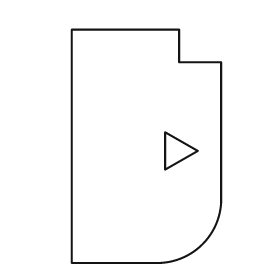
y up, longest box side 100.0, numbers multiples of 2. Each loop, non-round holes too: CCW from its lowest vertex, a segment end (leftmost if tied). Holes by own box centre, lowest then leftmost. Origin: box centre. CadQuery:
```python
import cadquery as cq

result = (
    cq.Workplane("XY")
    .moveTo(-32.0, -50.0)
    .lineTo(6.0, -50.0)
    .threePointArc((24.0, -42.0), (32.0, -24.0))
    .lineTo(32.0, 36.0)
    .lineTo(14.0, 36.0)
    .lineTo(14.0, 50.0)
    .lineTo(-32.0, 50.0)
    .close()
    .moveTo(8.0, -10.0)
    .lineTo(22.0, -2.0)
    .lineTo(8.0, 6.0)
    .close()
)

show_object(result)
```